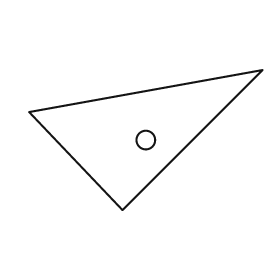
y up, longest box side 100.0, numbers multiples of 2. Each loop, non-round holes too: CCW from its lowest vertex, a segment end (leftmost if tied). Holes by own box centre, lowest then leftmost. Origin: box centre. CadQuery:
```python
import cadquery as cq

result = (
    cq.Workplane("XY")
    .moveTo(-10.0, -30.0)
    .lineTo(50.0, 30.0)
    .lineTo(-50.0, 12.0)
    .close()
    .moveTo(0.0, 0.0)
    .circle(4.0)
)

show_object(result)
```